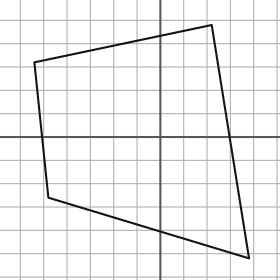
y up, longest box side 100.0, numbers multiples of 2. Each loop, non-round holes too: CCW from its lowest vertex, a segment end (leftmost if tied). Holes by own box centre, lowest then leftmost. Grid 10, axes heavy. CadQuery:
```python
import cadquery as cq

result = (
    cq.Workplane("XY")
    .moveTo(38.0, -52.0)
    .lineTo(22.0, 48.0)
    .lineTo(-54.0, 32.0)
    .lineTo(-48.0, -26.0)
    .close()
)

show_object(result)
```